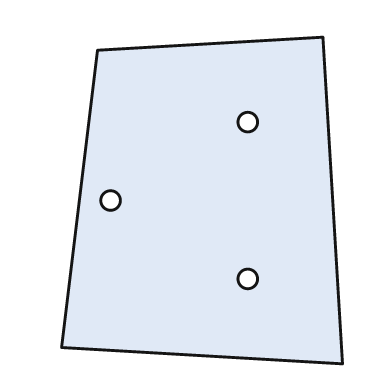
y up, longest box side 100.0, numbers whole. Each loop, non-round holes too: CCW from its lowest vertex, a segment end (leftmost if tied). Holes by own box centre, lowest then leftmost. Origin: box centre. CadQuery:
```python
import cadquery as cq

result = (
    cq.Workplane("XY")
    .moveTo(43.0, -50.0)
    .lineTo(37.0, 50.0)
    .lineTo(-32.0, 46.0)
    .lineTo(-43.0, -45.0)
    .close()
    .moveTo(14.0, -24.0)
    .circle(3.0)
    .moveTo(-28.0, 0.0)
    .circle(3.0)
    .moveTo(14.0, 24.0)
    .circle(3.0)
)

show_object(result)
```